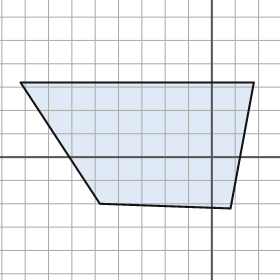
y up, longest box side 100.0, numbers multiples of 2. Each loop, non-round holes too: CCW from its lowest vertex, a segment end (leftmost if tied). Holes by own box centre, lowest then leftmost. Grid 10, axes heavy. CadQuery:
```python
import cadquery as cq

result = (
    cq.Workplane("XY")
    .moveTo(8.0, -22.0)
    .lineTo(18.0, 32.0)
    .lineTo(-82.0, 32.0)
    .lineTo(-48.0, -20.0)
    .close()
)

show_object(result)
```